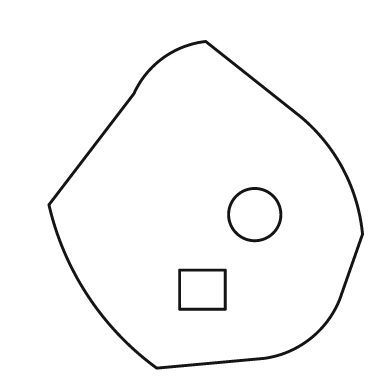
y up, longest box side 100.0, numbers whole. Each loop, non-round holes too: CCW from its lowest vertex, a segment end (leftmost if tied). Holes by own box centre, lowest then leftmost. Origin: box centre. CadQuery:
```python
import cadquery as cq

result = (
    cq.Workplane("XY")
    .moveTo(-15.0, -50.0)
    .lineTo(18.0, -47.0)
    .threePointArc((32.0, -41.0), (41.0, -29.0))
    .lineTo(48.0, -9.0)
    .threePointArc((42.0, 11.0), (29.0, 27.0))
    .lineTo(0.0, 50.0)
    .threePointArc((-13.0, 45.0), (-22.0, 34.0))
    .lineTo(-48.0, 0.0)
    .threePointArc((-36.0, -28.0), (-15.0, -50.0))
    .close()
    .moveTo(-8.0, -32.0)
    .lineTo(6.0, -32.0)
    .lineTo(6.0, -20.0)
    .lineTo(-8.0, -20.0)
    .close()
    .moveTo(15.0, -3.0)
    .circle(8.0)
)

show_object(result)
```